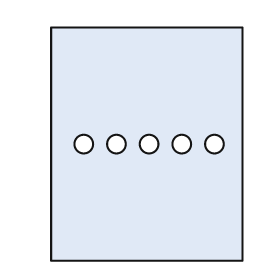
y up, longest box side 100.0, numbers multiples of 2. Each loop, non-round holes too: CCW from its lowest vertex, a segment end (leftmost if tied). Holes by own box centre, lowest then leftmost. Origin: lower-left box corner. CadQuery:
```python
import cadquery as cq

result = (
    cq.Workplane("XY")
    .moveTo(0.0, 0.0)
    .lineTo(82.0, 0.0)
    .lineTo(82.0, 100.0)
    .lineTo(0.0, 100.0)
    .close()
    .moveTo(14.0, 50.0)
    .circle(4.0)
    .moveTo(28.0, 50.0)
    .circle(4.0)
    .moveTo(42.0, 50.0)
    .circle(4.0)
    .moveTo(56.0, 50.0)
    .circle(4.0)
    .moveTo(70.0, 50.0)
    .circle(4.0)
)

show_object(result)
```